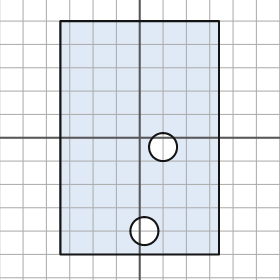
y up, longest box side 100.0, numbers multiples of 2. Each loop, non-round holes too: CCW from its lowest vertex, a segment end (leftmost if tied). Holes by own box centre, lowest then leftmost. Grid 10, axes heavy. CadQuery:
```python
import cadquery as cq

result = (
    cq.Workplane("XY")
    .moveTo(-34.0, -50.0)
    .lineTo(34.0, -50.0)
    .lineTo(34.0, 50.0)
    .lineTo(-34.0, 50.0)
    .close()
    .moveTo(2.0, -40.0)
    .circle(6.0)
    .moveTo(10.0, -4.0)
    .circle(6.0)
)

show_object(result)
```